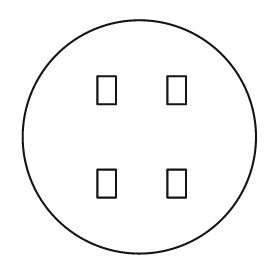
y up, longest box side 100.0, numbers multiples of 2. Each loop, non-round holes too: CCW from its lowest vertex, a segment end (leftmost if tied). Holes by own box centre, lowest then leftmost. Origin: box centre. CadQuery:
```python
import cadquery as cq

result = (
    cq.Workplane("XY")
    .moveTo(0.0, 0.0)
    .circle(50.0)
    .moveTo(-18.0, -26.0)
    .lineTo(-10.0, -26.0)
    .lineTo(-10.0, -14.0)
    .lineTo(-18.0, -14.0)
    .close()
    .moveTo(12.0, -26.0)
    .lineTo(20.0, -26.0)
    .lineTo(20.0, -14.0)
    .lineTo(12.0, -14.0)
    .close()
    .moveTo(-18.0, 14.0)
    .lineTo(-10.0, 14.0)
    .lineTo(-10.0, 26.0)
    .lineTo(-18.0, 26.0)
    .close()
    .moveTo(12.0, 14.0)
    .lineTo(20.0, 14.0)
    .lineTo(20.0, 26.0)
    .lineTo(12.0, 26.0)
    .close()
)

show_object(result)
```